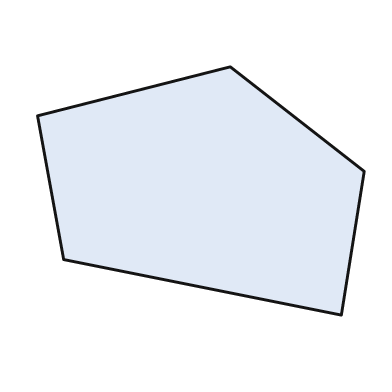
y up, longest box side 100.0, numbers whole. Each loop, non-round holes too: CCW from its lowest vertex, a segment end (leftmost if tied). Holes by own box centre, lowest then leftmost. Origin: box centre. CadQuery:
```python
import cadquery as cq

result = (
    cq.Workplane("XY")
    .moveTo(43.0, -38.0)
    .lineTo(50.0, 6.0)
    .lineTo(9.0, 38.0)
    .lineTo(-50.0, 23.0)
    .lineTo(-42.0, -21.0)
    .close()
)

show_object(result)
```